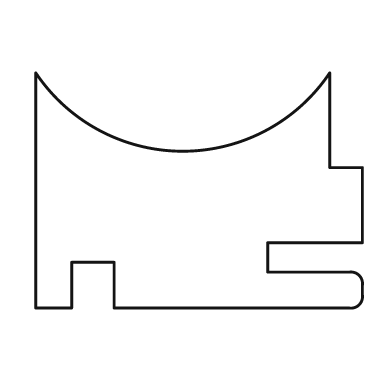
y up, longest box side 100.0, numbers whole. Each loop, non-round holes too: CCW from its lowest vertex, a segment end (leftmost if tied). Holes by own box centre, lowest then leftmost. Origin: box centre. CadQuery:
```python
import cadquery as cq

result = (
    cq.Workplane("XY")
    .moveTo(-50.0, -36.0)
    .lineTo(-39.0, -36.0)
    .lineTo(-39.0, -22.0)
    .lineTo(-26.0, -22.0)
    .lineTo(-26.0, -36.0)
    .lineTo(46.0, -36.0)
    .threePointArc((49.0, -35.0), (50.0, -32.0))
    .lineTo(50.0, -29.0)
    .threePointArc((49.0, -26.0), (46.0, -25.0))
    .lineTo(21.0, -25.0)
    .lineTo(21.0, -16.0)
    .lineTo(50.0, -16.0)
    .lineTo(50.0, 7.0)
    .lineTo(40.0, 7.0)
    .lineTo(40.0, 36.0)
    .threePointArc((-5.0, 12.0), (-50.0, 36.0))
    .close()
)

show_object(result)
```